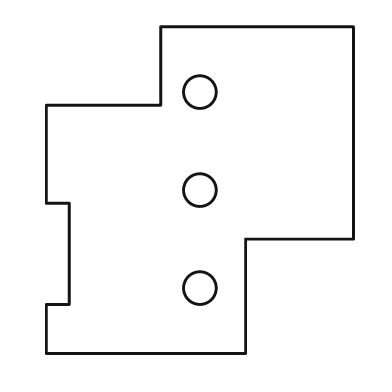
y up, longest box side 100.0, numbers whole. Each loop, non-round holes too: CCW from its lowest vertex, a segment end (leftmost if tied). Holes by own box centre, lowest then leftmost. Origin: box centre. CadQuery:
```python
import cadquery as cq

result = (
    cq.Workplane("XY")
    .moveTo(-47.0, -50.0)
    .lineTo(14.0, -50.0)
    .lineTo(14.0, -15.0)
    .lineTo(47.0, -15.0)
    .lineTo(47.0, 50.0)
    .lineTo(-12.0, 50.0)
    .lineTo(-12.0, 26.0)
    .lineTo(-47.0, 26.0)
    .lineTo(-47.0, -4.0)
    .lineTo(-40.0, -4.0)
    .lineTo(-40.0, -35.0)
    .lineTo(-47.0, -35.0)
    .close()
    .moveTo(0.0, -30.0)
    .circle(5.0)
    .moveTo(0.0, 0.0)
    .circle(5.0)
    .moveTo(0.0, 30.0)
    .circle(5.0)
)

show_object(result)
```